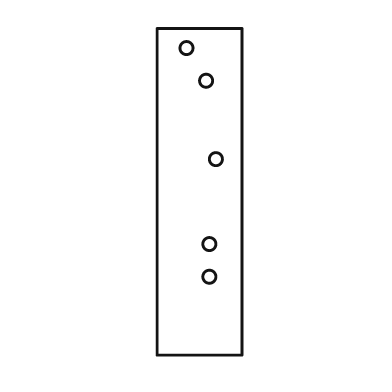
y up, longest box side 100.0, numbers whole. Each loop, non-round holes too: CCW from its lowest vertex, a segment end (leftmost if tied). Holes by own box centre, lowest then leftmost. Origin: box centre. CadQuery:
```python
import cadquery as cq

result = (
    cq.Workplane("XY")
    .moveTo(-13.0, -50.0)
    .lineTo(13.0, -50.0)
    .lineTo(13.0, 50.0)
    .lineTo(-13.0, 50.0)
    .close()
    .moveTo(3.0, -26.0)
    .circle(2.0)
    .moveTo(3.0, -16.0)
    .circle(2.0)
    .moveTo(5.0, 10.0)
    .circle(2.0)
    .moveTo(2.0, 34.0)
    .circle(2.0)
    .moveTo(-4.0, 44.0)
    .circle(2.0)
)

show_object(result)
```